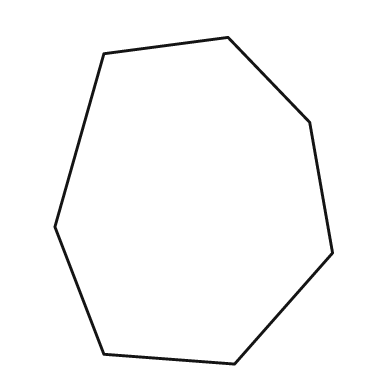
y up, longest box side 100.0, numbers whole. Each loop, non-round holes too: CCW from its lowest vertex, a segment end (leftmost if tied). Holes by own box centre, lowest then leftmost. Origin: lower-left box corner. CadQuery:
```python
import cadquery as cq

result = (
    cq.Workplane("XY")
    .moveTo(55.0, 0.0)
    .lineTo(85.0, 34.0)
    .lineTo(78.0, 74.0)
    .lineTo(53.0, 100.0)
    .lineTo(15.0, 95.0)
    .lineTo(0.0, 42.0)
    .lineTo(15.0, 3.0)
    .close()
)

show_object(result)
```